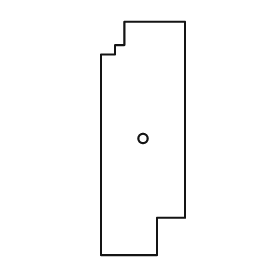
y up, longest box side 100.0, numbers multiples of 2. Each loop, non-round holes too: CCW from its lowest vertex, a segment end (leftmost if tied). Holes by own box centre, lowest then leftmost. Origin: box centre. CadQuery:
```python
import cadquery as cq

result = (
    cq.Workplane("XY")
    .moveTo(-18.0, -50.0)
    .lineTo(6.0, -50.0)
    .lineTo(6.0, -34.0)
    .lineTo(18.0, -34.0)
    .lineTo(18.0, 50.0)
    .lineTo(-8.0, 50.0)
    .lineTo(-8.0, 40.0)
    .lineTo(-12.0, 40.0)
    .lineTo(-12.0, 36.0)
    .lineTo(-18.0, 36.0)
    .close()
    .moveTo(0.0, 0.0)
    .circle(2.0)
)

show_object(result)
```